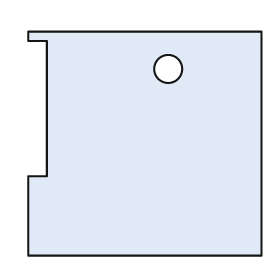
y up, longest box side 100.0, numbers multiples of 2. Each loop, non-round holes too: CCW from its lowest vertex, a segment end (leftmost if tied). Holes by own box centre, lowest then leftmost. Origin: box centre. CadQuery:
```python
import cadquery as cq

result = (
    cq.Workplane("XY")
    .moveTo(-50.0, -48.0)
    .lineTo(50.0, -48.0)
    .lineTo(50.0, 48.0)
    .lineTo(-50.0, 48.0)
    .lineTo(-50.0, 44.0)
    .lineTo(-42.0, 44.0)
    .lineTo(-42.0, -14.0)
    .lineTo(-50.0, -14.0)
    .close()
    .moveTo(10.0, 32.0)
    .circle(6.0)
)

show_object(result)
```